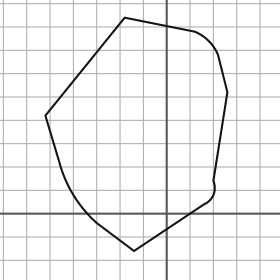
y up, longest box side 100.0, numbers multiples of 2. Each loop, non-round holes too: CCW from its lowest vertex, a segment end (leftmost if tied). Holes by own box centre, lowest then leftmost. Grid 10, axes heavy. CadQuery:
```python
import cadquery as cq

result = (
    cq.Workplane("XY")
    .moveTo(-14.0, -16.0)
    .lineTo(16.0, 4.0)
    .threePointArc((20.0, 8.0), (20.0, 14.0))
    .lineTo(26.0, 52.0)
    .lineTo(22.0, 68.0)
    .threePointArc((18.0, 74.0), (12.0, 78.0))
    .lineTo(-18.0, 84.0)
    .lineTo(-52.0, 42.0)
    .lineTo(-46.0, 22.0)
    .threePointArc((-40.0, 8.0), (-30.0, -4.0))
    .close()
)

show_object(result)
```